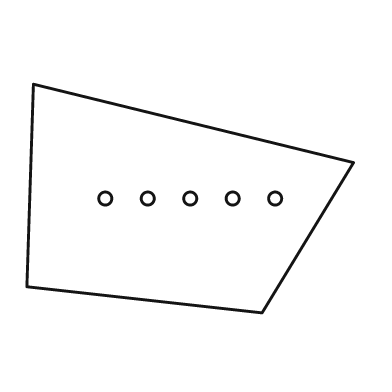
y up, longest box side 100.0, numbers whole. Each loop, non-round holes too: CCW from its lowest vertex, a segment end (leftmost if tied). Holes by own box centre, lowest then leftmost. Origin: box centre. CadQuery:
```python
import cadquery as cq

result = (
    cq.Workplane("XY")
    .moveTo(22.0, -35.0)
    .lineTo(50.0, 11.0)
    .lineTo(-48.0, 35.0)
    .lineTo(-50.0, -27.0)
    .close()
    .moveTo(-26.0, 0.0)
    .circle(2.0)
    .moveTo(-13.0, 0.0)
    .circle(2.0)
    .moveTo(0.0, 0.0)
    .circle(2.0)
    .moveTo(13.0, 0.0)
    .circle(2.0)
    .moveTo(26.0, 0.0)
    .circle(2.0)
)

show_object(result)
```